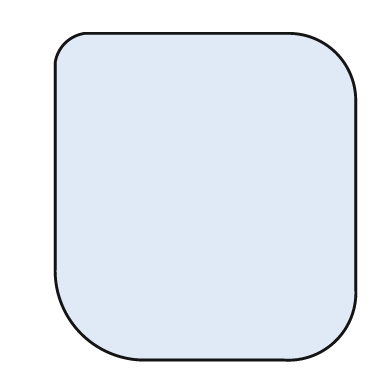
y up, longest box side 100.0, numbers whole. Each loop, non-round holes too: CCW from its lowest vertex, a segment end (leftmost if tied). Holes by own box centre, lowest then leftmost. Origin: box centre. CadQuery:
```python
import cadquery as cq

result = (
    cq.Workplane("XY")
    .moveTo(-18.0, -50.0)
    .lineTo(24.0, -50.0)
    .threePointArc((40.0, -44.0), (46.0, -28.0))
    .lineTo(46.0, 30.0)
    .threePointArc((40.0, 44.0), (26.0, 50.0))
    .lineTo(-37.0, 50.0)
    .threePointArc((-43.0, 47.0), (-46.0, 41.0))
    .lineTo(-46.0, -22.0)
    .threePointArc((-38.0, -42.0), (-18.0, -50.0))
    .close()
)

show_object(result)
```